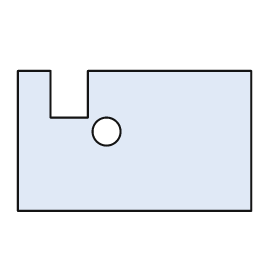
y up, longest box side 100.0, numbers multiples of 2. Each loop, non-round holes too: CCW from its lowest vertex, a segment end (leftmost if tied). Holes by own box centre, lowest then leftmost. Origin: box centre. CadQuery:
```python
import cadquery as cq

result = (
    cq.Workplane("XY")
    .moveTo(-50.0, -30.0)
    .lineTo(50.0, -30.0)
    .lineTo(50.0, 30.0)
    .lineTo(-20.0, 30.0)
    .lineTo(-20.0, 10.0)
    .lineTo(-36.0, 10.0)
    .lineTo(-36.0, 30.0)
    .lineTo(-50.0, 30.0)
    .close()
    .moveTo(-12.0, 4.0)
    .circle(6.0)
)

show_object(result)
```